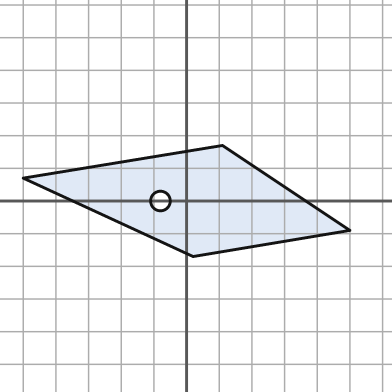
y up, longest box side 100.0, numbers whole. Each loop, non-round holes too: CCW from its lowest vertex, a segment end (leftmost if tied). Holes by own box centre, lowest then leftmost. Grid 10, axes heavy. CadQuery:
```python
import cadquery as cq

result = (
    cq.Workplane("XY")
    .moveTo(2.0, -17.0)
    .lineTo(50.0, -9.0)
    .lineTo(11.0, 17.0)
    .lineTo(-50.0, 7.0)
    .close()
    .moveTo(-8.0, 0.0)
    .circle(3.0)
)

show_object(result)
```